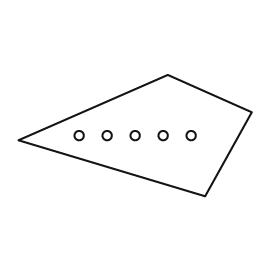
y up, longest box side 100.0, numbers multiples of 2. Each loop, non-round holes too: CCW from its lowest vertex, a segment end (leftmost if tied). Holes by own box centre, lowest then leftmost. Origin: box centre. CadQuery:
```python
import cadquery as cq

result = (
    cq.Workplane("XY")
    .moveTo(30.0, -26.0)
    .lineTo(50.0, 10.0)
    .lineTo(14.0, 26.0)
    .lineTo(-50.0, -2.0)
    .close()
    .moveTo(-24.0, 0.0)
    .circle(2.0)
    .moveTo(-12.0, 0.0)
    .circle(2.0)
    .moveTo(0.0, 0.0)
    .circle(2.0)
    .moveTo(12.0, 0.0)
    .circle(2.0)
    .moveTo(24.0, 0.0)
    .circle(2.0)
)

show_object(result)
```